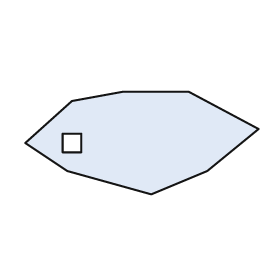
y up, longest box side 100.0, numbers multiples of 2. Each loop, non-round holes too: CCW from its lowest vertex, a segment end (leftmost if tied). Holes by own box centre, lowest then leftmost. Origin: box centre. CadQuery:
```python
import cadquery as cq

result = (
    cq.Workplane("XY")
    .moveTo(4.0, -22.0)
    .lineTo(28.0, -12.0)
    .lineTo(50.0, 6.0)
    .lineTo(20.0, 22.0)
    .lineTo(-8.0, 22.0)
    .lineTo(-30.0, 18.0)
    .lineTo(-50.0, 0.0)
    .lineTo(-32.0, -12.0)
    .close()
    .moveTo(-34.0, -4.0)
    .lineTo(-26.0, -4.0)
    .lineTo(-26.0, 4.0)
    .lineTo(-34.0, 4.0)
    .close()
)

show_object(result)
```